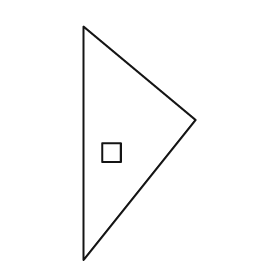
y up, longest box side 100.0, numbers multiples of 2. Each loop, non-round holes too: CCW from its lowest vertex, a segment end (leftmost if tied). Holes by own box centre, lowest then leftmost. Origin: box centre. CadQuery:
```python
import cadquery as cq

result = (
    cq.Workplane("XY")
    .moveTo(-24.0, -50.0)
    .lineTo(24.0, 10.0)
    .lineTo(-24.0, 50.0)
    .close()
    .moveTo(-16.0, -8.0)
    .lineTo(-8.0, -8.0)
    .lineTo(-8.0, 0.0)
    .lineTo(-16.0, 0.0)
    .close()
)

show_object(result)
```